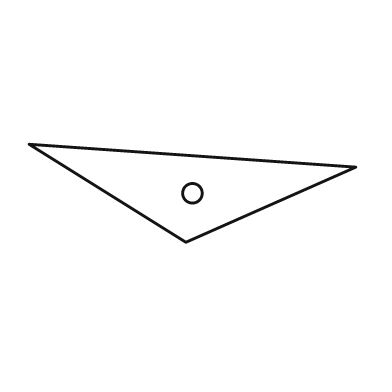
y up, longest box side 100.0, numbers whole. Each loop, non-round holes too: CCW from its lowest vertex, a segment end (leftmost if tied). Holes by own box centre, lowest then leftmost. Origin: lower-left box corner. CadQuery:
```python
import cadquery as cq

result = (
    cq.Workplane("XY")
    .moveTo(48.0, 0.0)
    .lineTo(100.0, 23.0)
    .lineTo(0.0, 30.0)
    .close()
    .moveTo(50.0, 15.0)
    .circle(3.0)
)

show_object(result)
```